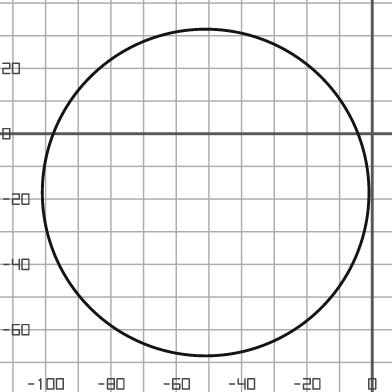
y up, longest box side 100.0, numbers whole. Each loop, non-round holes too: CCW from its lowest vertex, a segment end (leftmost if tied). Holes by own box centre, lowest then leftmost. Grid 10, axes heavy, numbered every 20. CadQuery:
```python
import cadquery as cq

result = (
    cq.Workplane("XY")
    .moveTo(-51.0, -18.0)
    .circle(50.0)
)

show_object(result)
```